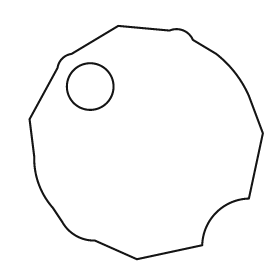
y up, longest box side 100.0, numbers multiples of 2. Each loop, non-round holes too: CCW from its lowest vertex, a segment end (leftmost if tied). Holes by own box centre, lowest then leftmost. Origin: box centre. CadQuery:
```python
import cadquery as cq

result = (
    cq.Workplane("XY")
    .moveTo(-4.0, -50.0)
    .lineTo(24.0, -44.0)
    .threePointArc((30.0, -30.0), (44.0, -24.0))
    .lineTo(50.0, 4.0)
    .lineTo(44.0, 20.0)
    .threePointArc((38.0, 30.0), (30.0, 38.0))
    .lineTo(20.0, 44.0)
    .threePointArc((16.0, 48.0), (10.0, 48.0))
    .lineTo(-12.0, 50.0)
    .lineTo(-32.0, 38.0)
    .threePointArc((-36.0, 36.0), (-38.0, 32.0))
    .lineTo(-50.0, 10.0)
    .lineTo(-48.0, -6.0)
    .threePointArc((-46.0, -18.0), (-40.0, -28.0))
    .lineTo(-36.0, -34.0)
    .threePointArc((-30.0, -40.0), (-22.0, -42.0))
    .close()
    .moveTo(-24.0, 24.0)
    .circle(10.0)
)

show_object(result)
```